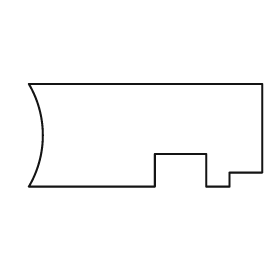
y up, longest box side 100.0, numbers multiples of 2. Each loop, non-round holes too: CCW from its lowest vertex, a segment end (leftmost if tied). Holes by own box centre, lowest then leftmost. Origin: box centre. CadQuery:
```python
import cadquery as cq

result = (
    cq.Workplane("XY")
    .moveTo(-50.0, -22.0)
    .lineTo(4.0, -22.0)
    .lineTo(4.0, -8.0)
    .lineTo(26.0, -8.0)
    .lineTo(26.0, -22.0)
    .lineTo(36.0, -22.0)
    .lineTo(36.0, -16.0)
    .lineTo(50.0, -16.0)
    .lineTo(50.0, 22.0)
    .lineTo(-50.0, 22.0)
    .threePointArc((-44.0, 0.0), (-50.0, -22.0))
    .close()
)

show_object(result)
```